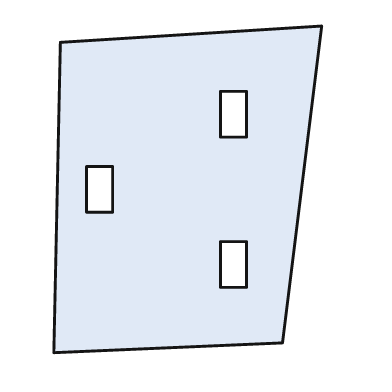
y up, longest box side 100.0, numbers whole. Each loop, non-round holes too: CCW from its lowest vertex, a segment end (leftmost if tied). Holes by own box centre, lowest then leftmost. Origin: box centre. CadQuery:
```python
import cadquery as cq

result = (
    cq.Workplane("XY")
    .moveTo(-41.0, -50.0)
    .lineTo(29.0, -47.0)
    .lineTo(41.0, 50.0)
    .lineTo(-39.0, 45.0)
    .close()
    .moveTo(10.0, -30.0)
    .lineTo(18.0, -30.0)
    .lineTo(18.0, -16.0)
    .lineTo(10.0, -16.0)
    .close()
    .moveTo(-31.0, -7.0)
    .lineTo(-23.0, -7.0)
    .lineTo(-23.0, 7.0)
    .lineTo(-31.0, 7.0)
    .close()
    .moveTo(10.0, 16.0)
    .lineTo(18.0, 16.0)
    .lineTo(18.0, 30.0)
    .lineTo(10.0, 30.0)
    .close()
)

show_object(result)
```